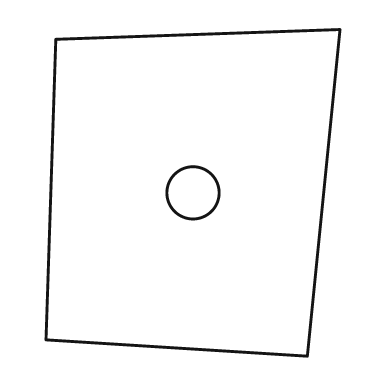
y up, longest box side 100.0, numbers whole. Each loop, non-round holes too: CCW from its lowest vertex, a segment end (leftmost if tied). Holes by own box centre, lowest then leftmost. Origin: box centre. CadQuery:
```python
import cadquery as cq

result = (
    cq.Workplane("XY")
    .moveTo(35.0, -50.0)
    .lineTo(45.0, 50.0)
    .lineTo(-42.0, 47.0)
    .lineTo(-45.0, -45.0)
    .close()
    .moveTo(0.0, 0.0)
    .circle(8.0)
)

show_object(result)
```